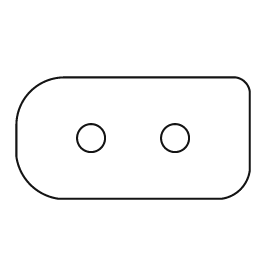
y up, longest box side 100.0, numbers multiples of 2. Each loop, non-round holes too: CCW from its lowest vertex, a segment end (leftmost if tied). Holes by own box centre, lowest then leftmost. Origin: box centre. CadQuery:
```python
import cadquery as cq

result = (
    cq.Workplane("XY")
    .moveTo(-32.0, -26.0)
    .lineTo(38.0, -26.0)
    .threePointArc((46.0, -22.0), (50.0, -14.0))
    .lineTo(50.0, 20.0)
    .threePointArc((48.0, 24.0), (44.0, 26.0))
    .lineTo(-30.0, 26.0)
    .threePointArc((-44.0, 20.0), (-50.0, 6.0))
    .lineTo(-50.0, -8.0)
    .threePointArc((-44.0, -20.0), (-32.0, -26.0))
    .close()
    .moveTo(-18.0, 0.0)
    .circle(6.0)
    .moveTo(18.0, 0.0)
    .circle(6.0)
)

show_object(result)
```